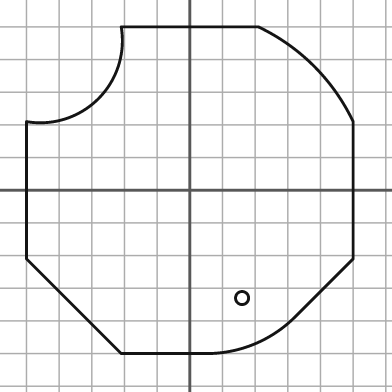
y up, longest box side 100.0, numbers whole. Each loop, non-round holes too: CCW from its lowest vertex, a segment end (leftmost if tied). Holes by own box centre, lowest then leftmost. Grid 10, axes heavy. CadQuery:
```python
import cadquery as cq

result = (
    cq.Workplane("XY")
    .moveTo(-21.0, -50.0)
    .lineTo(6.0, -50.0)
    .threePointArc((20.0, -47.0), (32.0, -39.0))
    .lineTo(50.0, -21.0)
    .lineTo(50.0, 21.0)
    .threePointArc((38.0, 38.0), (21.0, 50.0))
    .lineTo(-21.0, 50.0)
    .threePointArc((-28.0, 28.0), (-50.0, 21.0))
    .lineTo(-50.0, -21.0)
    .close()
    .moveTo(16.0, -33.0)
    .circle(2.0)
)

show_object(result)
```